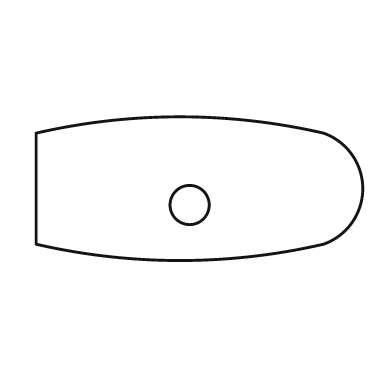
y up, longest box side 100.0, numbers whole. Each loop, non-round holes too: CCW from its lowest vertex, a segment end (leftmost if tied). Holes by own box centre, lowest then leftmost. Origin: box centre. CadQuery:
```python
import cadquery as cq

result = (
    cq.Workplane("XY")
    .moveTo(-50.0, -17.0)
    .threePointArc((-6.0, -22.0), (38.0, -17.0))
    .threePointArc((50.0, 0.0), (38.0, 17.0))
    .threePointArc((-6.0, 22.0), (-50.0, 17.0))
    .close()
    .moveTo(-3.0, -5.0)
    .circle(6.0)
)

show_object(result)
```